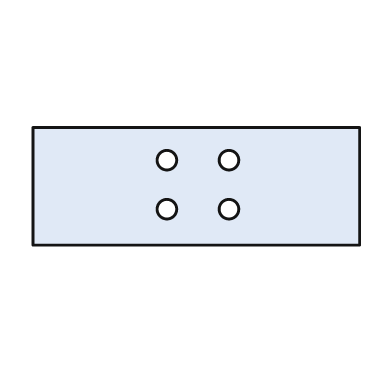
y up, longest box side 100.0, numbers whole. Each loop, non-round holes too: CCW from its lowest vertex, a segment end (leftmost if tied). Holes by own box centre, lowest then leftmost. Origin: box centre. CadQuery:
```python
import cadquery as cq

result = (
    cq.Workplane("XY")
    .moveTo(-50.0, -18.0)
    .lineTo(50.0, -18.0)
    .lineTo(50.0, 18.0)
    .lineTo(-50.0, 18.0)
    .close()
    .moveTo(-9.0, -7.0)
    .circle(3.0)
    .moveTo(10.0, -7.0)
    .circle(3.0)
    .moveTo(-9.0, 8.0)
    .circle(3.0)
    .moveTo(10.0, 8.0)
    .circle(3.0)
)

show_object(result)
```